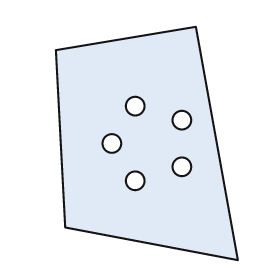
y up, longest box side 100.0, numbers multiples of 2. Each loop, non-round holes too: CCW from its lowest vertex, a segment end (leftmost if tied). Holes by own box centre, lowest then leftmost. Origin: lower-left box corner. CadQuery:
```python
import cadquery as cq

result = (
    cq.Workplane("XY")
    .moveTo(78.0, 0.0)
    .lineTo(60.0, 100.0)
    .lineTo(0.0, 90.0)
    .lineTo(4.0, 14.0)
    .close()
    .moveTo(34.0, 34.0)
    .circle(4.0)
    .moveTo(54.0, 40.0)
    .circle(4.0)
    .moveTo(24.0, 50.0)
    .circle(4.0)
    .moveTo(54.0, 60.0)
    .circle(4.0)
    .moveTo(34.0, 66.0)
    .circle(4.0)
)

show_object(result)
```